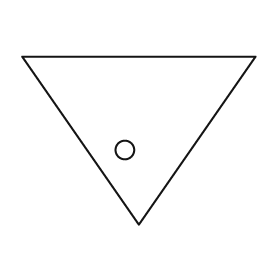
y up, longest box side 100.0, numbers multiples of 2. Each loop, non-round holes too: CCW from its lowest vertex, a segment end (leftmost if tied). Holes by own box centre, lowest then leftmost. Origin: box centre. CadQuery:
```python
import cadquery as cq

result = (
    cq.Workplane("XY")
    .moveTo(0.0, -36.0)
    .lineTo(50.0, 36.0)
    .lineTo(-50.0, 36.0)
    .close()
    .moveTo(-6.0, -4.0)
    .circle(4.0)
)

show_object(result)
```